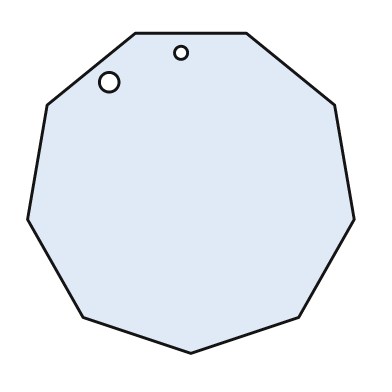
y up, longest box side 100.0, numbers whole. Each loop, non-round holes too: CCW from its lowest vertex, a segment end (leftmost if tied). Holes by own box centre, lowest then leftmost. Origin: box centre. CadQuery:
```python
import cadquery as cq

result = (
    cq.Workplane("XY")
    .moveTo(0.0, -49.0)
    .lineTo(33.0, -38.0)
    .lineTo(50.0, -8.0)
    .lineTo(44.0, 27.0)
    .lineTo(17.0, 49.0)
    .lineTo(-17.0, 49.0)
    .lineTo(-44.0, 27.0)
    .lineTo(-50.0, -8.0)
    .lineTo(-33.0, -38.0)
    .close()
    .moveTo(-25.0, 34.0)
    .circle(3.0)
    .moveTo(-3.0, 43.0)
    .circle(2.0)
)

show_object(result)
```